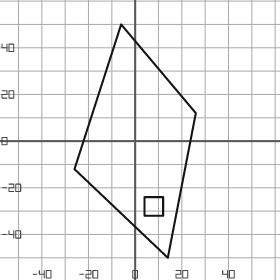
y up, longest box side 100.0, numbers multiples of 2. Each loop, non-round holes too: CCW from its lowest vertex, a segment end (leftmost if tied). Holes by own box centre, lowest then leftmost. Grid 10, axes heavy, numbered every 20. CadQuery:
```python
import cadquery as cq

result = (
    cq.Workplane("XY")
    .moveTo(14.0, -50.0)
    .lineTo(26.0, 12.0)
    .lineTo(-6.0, 50.0)
    .lineTo(-26.0, -12.0)
    .close()
    .moveTo(4.0, -32.0)
    .lineTo(12.0, -32.0)
    .lineTo(12.0, -24.0)
    .lineTo(4.0, -24.0)
    .close()
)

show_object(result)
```